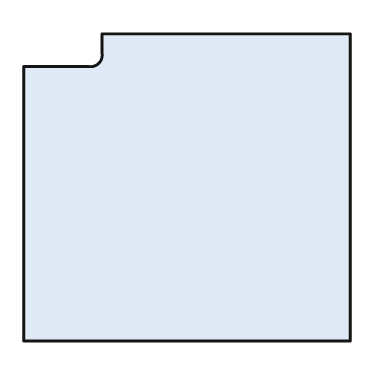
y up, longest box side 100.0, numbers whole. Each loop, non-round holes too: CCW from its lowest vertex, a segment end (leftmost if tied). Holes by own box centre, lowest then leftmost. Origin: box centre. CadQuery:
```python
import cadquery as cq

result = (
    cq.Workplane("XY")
    .moveTo(-50.0, -47.0)
    .lineTo(50.0, -47.0)
    .lineTo(50.0, 47.0)
    .lineTo(-26.0, 47.0)
    .lineTo(-26.0, 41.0)
    .threePointArc((-27.0, 38.0), (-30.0, 37.0))
    .lineTo(-50.0, 37.0)
    .close()
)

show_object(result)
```